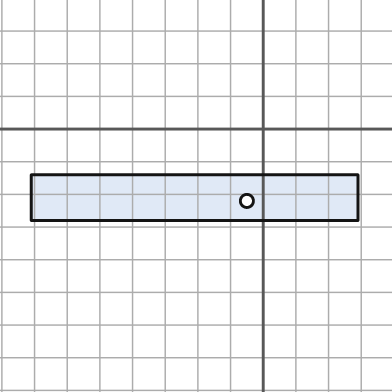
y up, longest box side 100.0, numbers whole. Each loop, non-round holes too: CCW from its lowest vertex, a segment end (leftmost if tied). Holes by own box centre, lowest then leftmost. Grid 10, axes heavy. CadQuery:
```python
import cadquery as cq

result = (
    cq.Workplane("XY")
    .moveTo(-71.0, -28.0)
    .lineTo(29.0, -28.0)
    .lineTo(29.0, -14.0)
    .lineTo(-71.0, -14.0)
    .close()
    .moveTo(-5.0, -22.0)
    .circle(2.0)
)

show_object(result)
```